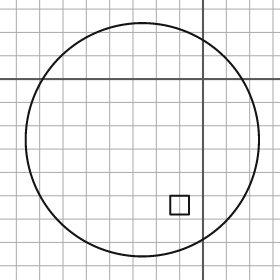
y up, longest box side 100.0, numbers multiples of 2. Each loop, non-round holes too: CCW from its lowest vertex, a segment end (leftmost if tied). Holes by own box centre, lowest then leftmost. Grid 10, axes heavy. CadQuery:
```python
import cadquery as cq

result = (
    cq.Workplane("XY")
    .moveTo(-26.0, -26.0)
    .circle(50.0)
    .moveTo(-14.0, -58.0)
    .lineTo(-6.0, -58.0)
    .lineTo(-6.0, -50.0)
    .lineTo(-14.0, -50.0)
    .close()
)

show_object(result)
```